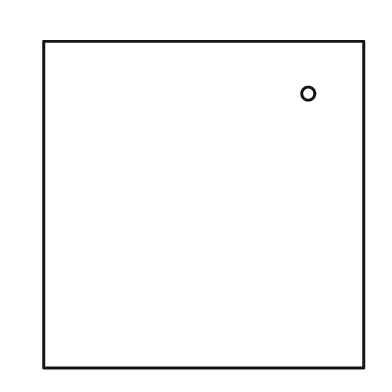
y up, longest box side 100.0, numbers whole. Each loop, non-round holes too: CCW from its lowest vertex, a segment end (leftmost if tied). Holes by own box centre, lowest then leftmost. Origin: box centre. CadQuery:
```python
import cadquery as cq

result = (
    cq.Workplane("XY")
    .moveTo(-49.0, -50.0)
    .lineTo(49.0, -50.0)
    .lineTo(49.0, 50.0)
    .lineTo(-49.0, 50.0)
    .close()
    .moveTo(32.0, 34.0)
    .circle(2.0)
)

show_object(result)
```